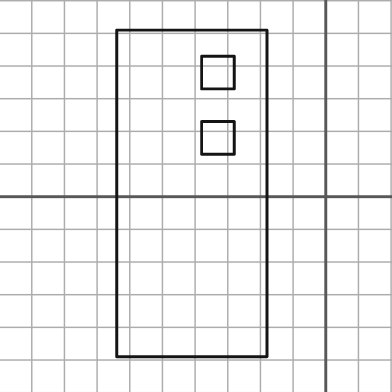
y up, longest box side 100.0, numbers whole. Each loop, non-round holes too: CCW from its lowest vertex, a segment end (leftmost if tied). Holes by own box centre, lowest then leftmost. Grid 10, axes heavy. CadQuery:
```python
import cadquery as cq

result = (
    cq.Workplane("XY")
    .moveTo(-64.0, -49.0)
    .lineTo(-18.0, -49.0)
    .lineTo(-18.0, 51.0)
    .lineTo(-64.0, 51.0)
    .close()
    .moveTo(-38.0, 13.0)
    .lineTo(-28.0, 13.0)
    .lineTo(-28.0, 23.0)
    .lineTo(-38.0, 23.0)
    .close()
    .moveTo(-38.0, 33.0)
    .lineTo(-28.0, 33.0)
    .lineTo(-28.0, 43.0)
    .lineTo(-38.0, 43.0)
    .close()
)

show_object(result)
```